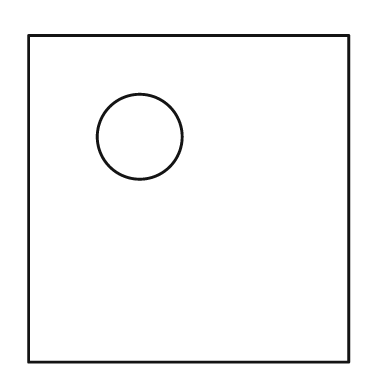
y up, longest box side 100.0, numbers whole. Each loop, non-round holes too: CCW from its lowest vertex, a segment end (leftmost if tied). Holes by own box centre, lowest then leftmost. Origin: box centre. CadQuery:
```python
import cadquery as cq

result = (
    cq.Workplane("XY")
    .moveTo(-49.0, -50.0)
    .lineTo(49.0, -50.0)
    .lineTo(49.0, 50.0)
    .lineTo(-49.0, 50.0)
    .close()
    .moveTo(-15.0, 19.0)
    .circle(13.0)
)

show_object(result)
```